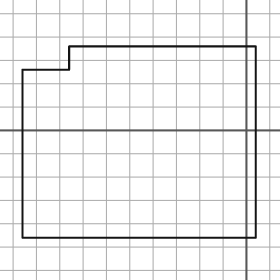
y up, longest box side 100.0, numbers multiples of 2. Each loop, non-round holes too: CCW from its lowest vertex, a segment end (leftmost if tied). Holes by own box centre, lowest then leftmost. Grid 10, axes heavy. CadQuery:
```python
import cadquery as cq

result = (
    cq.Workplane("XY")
    .moveTo(-96.0, -46.0)
    .lineTo(4.0, -46.0)
    .lineTo(4.0, 36.0)
    .lineTo(-76.0, 36.0)
    .lineTo(-76.0, 26.0)
    .lineTo(-96.0, 26.0)
    .close()
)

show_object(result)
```